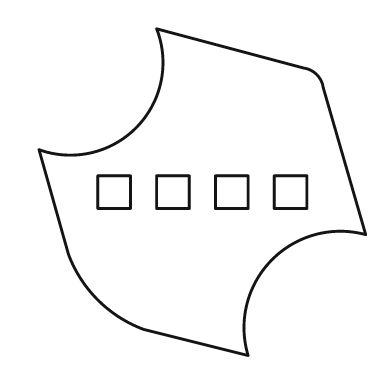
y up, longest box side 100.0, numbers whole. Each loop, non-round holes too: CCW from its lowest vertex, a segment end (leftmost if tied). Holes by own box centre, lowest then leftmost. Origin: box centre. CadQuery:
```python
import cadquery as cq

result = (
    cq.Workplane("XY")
    .moveTo(14.0, -50.0)
    .threePointArc((21.0, -21.0), (50.0, -13.0))
    .lineTo(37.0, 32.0)
    .threePointArc((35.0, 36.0), (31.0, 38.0))
    .lineTo(-14.0, 50.0)
    .threePointArc((-20.0, 20.0), (-50.0, 13.0))
    .lineTo(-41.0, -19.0)
    .threePointArc((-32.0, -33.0), (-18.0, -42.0))
    .close()
    .moveTo(-32.0, -5.0)
    .lineTo(-22.0, -5.0)
    .lineTo(-22.0, 5.0)
    .lineTo(-32.0, 5.0)
    .close()
    .moveTo(-14.0, -5.0)
    .lineTo(-4.0, -5.0)
    .lineTo(-4.0, 5.0)
    .lineTo(-14.0, 5.0)
    .close()
    .moveTo(4.0, -5.0)
    .lineTo(14.0, -5.0)
    .lineTo(14.0, 5.0)
    .lineTo(4.0, 5.0)
    .close()
    .moveTo(22.0, -5.0)
    .lineTo(32.0, -5.0)
    .lineTo(32.0, 5.0)
    .lineTo(22.0, 5.0)
    .close()
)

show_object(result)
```